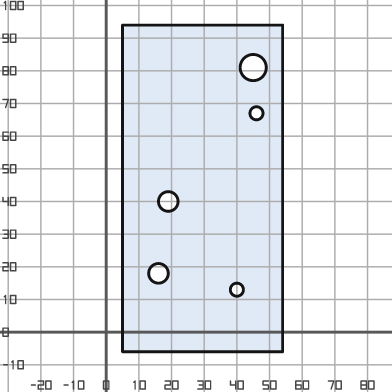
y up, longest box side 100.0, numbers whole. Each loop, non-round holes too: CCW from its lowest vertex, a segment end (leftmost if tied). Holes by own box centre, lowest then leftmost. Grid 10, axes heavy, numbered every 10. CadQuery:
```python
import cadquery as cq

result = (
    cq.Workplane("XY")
    .moveTo(5.0, -6.0)
    .lineTo(54.0, -6.0)
    .lineTo(54.0, 94.0)
    .lineTo(5.0, 94.0)
    .close()
    .moveTo(40.0, 13.0)
    .circle(2.0)
    .moveTo(16.0, 18.0)
    .circle(3.0)
    .moveTo(19.0, 40.0)
    .circle(3.0)
    .moveTo(46.0, 67.0)
    .circle(2.0)
    .moveTo(45.0, 81.0)
    .circle(4.0)
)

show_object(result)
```